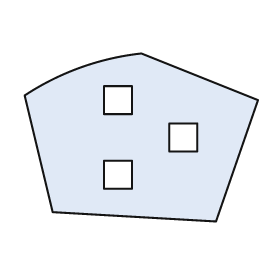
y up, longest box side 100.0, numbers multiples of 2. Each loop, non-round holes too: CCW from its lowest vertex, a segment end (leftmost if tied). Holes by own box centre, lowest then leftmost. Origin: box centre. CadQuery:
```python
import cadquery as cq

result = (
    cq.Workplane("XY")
    .moveTo(32.0, -36.0)
    .lineTo(50.0, 16.0)
    .lineTo(0.0, 36.0)
    .threePointArc((-26.0, 30.0), (-50.0, 18.0))
    .lineTo(-38.0, -32.0)
    .close()
    .moveTo(-16.0, -22.0)
    .lineTo(-4.0, -22.0)
    .lineTo(-4.0, -10.0)
    .lineTo(-16.0, -10.0)
    .close()
    .moveTo(12.0, -6.0)
    .lineTo(24.0, -6.0)
    .lineTo(24.0, 6.0)
    .lineTo(12.0, 6.0)
    .close()
    .moveTo(-16.0, 10.0)
    .lineTo(-4.0, 10.0)
    .lineTo(-4.0, 22.0)
    .lineTo(-16.0, 22.0)
    .close()
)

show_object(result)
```